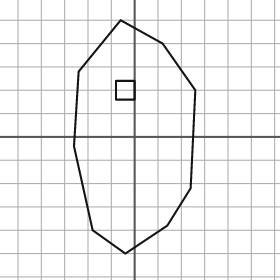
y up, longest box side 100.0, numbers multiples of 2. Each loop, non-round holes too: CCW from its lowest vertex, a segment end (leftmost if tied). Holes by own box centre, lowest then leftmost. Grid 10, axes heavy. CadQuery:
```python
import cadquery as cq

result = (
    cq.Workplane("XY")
    .moveTo(-4.0, -50.0)
    .lineTo(14.0, -38.0)
    .lineTo(24.0, -22.0)
    .lineTo(26.0, 20.0)
    .lineTo(12.0, 40.0)
    .lineTo(-6.0, 50.0)
    .lineTo(-24.0, 28.0)
    .lineTo(-26.0, -4.0)
    .lineTo(-18.0, -40.0)
    .close()
    .moveTo(-8.0, 16.0)
    .lineTo(0.0, 16.0)
    .lineTo(0.0, 24.0)
    .lineTo(-8.0, 24.0)
    .close()
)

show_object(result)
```